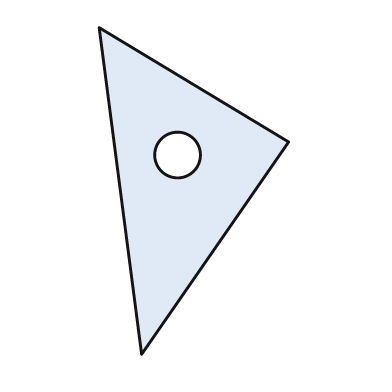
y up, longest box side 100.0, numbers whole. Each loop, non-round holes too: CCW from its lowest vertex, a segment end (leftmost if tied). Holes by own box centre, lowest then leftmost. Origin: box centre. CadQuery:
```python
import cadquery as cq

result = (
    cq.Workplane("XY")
    .moveTo(-16.0, -50.0)
    .lineTo(29.0, 15.0)
    .lineTo(-29.0, 50.0)
    .close()
    .moveTo(-5.0, 11.0)
    .circle(7.0)
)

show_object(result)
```